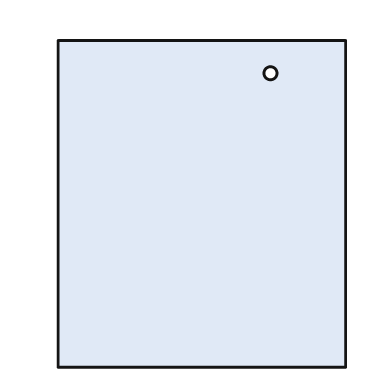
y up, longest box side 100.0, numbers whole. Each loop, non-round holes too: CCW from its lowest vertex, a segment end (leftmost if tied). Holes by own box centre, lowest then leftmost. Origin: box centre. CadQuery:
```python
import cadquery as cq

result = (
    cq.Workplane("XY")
    .moveTo(-44.0, -50.0)
    .lineTo(44.0, -50.0)
    .lineTo(44.0, 50.0)
    .lineTo(-44.0, 50.0)
    .close()
    .moveTo(21.0, 40.0)
    .circle(2.0)
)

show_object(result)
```